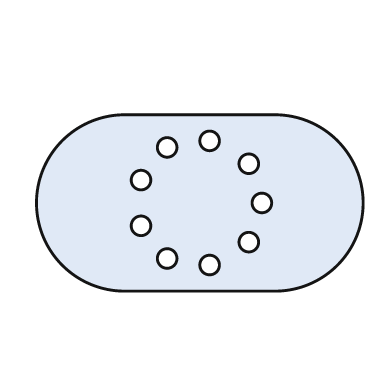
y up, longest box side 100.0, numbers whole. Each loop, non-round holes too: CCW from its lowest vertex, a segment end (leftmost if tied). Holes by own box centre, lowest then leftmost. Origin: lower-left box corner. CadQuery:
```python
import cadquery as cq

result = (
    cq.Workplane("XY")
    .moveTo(27.0, 0.0)
    .lineTo(73.0, 0.0)
    .threePointArc((100.0, 27.0), (73.0, 54.0))
    .lineTo(27.0, 54.0)
    .threePointArc((0.0, 27.0), (27.0, 0.0))
    .close()
    .moveTo(53.0, 8.0)
    .circle(3.0)
    .moveTo(40.0, 10.0)
    .circle(3.0)
    .moveTo(65.0, 15.0)
    .circle(3.0)
    .moveTo(32.0, 20.0)
    .circle(3.0)
    .moveTo(69.0, 27.0)
    .circle(3.0)
    .moveTo(32.0, 34.0)
    .circle(3.0)
    .moveTo(65.0, 39.0)
    .circle(3.0)
    .moveTo(40.0, 44.0)
    .circle(3.0)
    .moveTo(53.0, 46.0)
    .circle(3.0)
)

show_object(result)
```